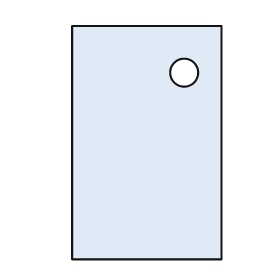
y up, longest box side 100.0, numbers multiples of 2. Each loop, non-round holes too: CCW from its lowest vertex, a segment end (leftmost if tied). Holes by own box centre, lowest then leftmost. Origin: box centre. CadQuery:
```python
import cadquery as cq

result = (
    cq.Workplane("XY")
    .moveTo(-32.0, -50.0)
    .lineTo(32.0, -50.0)
    .lineTo(32.0, 50.0)
    .lineTo(-32.0, 50.0)
    .close()
    .moveTo(16.0, 30.0)
    .circle(6.0)
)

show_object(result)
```